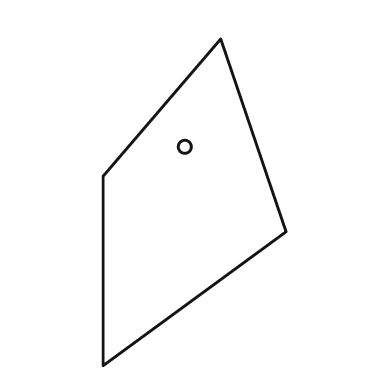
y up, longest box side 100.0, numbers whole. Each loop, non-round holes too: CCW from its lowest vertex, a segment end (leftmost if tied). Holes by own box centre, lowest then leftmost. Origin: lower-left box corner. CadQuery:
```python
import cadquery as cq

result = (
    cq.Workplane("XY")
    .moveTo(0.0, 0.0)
    .lineTo(56.0, 41.0)
    .lineTo(36.0, 100.0)
    .lineTo(0.0, 58.0)
    .close()
    .moveTo(25.0, 67.0)
    .circle(2.0)
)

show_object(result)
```